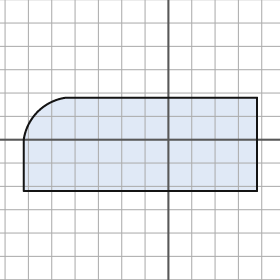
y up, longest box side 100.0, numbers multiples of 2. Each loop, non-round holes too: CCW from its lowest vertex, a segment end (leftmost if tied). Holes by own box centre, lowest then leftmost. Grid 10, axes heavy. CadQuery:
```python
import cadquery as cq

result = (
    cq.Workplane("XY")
    .moveTo(-62.0, -22.0)
    .lineTo(38.0, -22.0)
    .lineTo(38.0, 18.0)
    .lineTo(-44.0, 18.0)
    .threePointArc((-56.0, 12.0), (-62.0, 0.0))
    .close()
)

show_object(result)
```